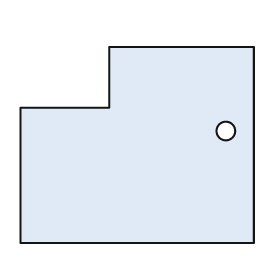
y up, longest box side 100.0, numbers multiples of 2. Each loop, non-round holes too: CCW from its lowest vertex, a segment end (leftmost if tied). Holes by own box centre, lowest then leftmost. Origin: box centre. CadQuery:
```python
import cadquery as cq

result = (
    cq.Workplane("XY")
    .moveTo(-50.0, -42.0)
    .lineTo(50.0, -42.0)
    .lineTo(50.0, 42.0)
    .lineTo(-12.0, 42.0)
    .lineTo(-12.0, 16.0)
    .lineTo(-50.0, 16.0)
    .close()
    .moveTo(38.0, 6.0)
    .circle(4.0)
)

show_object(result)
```